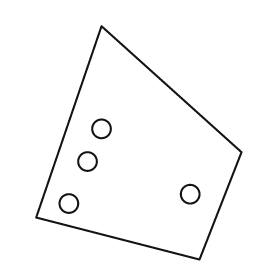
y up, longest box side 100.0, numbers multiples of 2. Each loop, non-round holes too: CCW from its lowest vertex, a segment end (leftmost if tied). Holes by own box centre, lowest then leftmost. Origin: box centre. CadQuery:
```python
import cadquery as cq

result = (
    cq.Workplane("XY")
    .moveTo(26.0, -50.0)
    .lineTo(44.0, -4.0)
    .lineTo(-16.0, 50.0)
    .lineTo(-44.0, -32.0)
    .close()
    .moveTo(-30.0, -26.0)
    .circle(4.0)
    .moveTo(22.0, -22.0)
    .circle(4.0)
    .moveTo(-22.0, -8.0)
    .circle(4.0)
    .moveTo(-16.0, 6.0)
    .circle(4.0)
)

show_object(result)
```